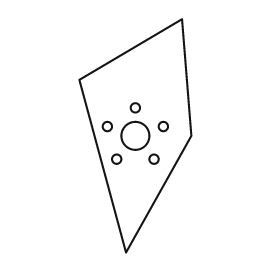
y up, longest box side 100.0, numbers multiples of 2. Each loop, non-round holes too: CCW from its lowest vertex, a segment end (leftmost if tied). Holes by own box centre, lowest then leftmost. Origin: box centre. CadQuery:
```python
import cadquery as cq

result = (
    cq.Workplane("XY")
    .moveTo(-4.0, -50.0)
    .lineTo(24.0, 0.0)
    .lineTo(20.0, 50.0)
    .lineTo(-24.0, 24.0)
    .close()
    .moveTo(-8.0, -10.0)
    .circle(2.0)
    .moveTo(8.0, -10.0)
    .circle(2.0)
    .moveTo(0.0, 0.0)
    .circle(6.0)
    .moveTo(-12.0, 4.0)
    .circle(2.0)
    .moveTo(12.0, 4.0)
    .circle(2.0)
    .moveTo(0.0, 12.0)
    .circle(2.0)
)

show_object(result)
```